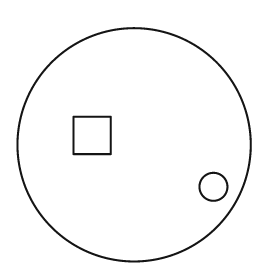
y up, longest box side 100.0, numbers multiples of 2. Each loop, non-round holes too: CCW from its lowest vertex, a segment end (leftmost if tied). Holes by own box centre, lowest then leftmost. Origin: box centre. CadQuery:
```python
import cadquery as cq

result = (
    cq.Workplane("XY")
    .moveTo(0.0, 0.0)
    .circle(50.0)
    .moveTo(34.0, -18.0)
    .circle(6.0)
    .moveTo(-26.0, -4.0)
    .lineTo(-10.0, -4.0)
    .lineTo(-10.0, 12.0)
    .lineTo(-26.0, 12.0)
    .close()
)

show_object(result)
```